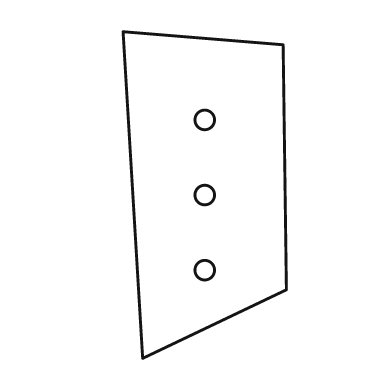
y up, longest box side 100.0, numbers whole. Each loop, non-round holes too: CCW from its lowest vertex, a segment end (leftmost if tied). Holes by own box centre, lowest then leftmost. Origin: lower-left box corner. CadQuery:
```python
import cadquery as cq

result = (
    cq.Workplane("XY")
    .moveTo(6.0, 0.0)
    .lineTo(50.0, 21.0)
    .lineTo(49.0, 96.0)
    .lineTo(0.0, 100.0)
    .close()
    .moveTo(25.0, 27.0)
    .circle(3.0)
    .moveTo(25.0, 50.0)
    .circle(3.0)
    .moveTo(25.0, 73.0)
    .circle(3.0)
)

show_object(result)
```